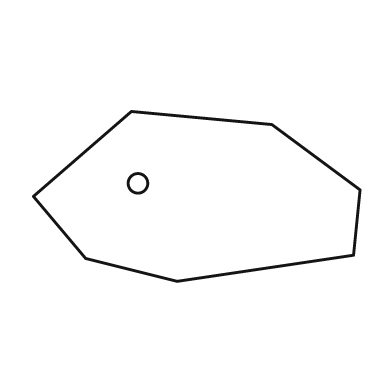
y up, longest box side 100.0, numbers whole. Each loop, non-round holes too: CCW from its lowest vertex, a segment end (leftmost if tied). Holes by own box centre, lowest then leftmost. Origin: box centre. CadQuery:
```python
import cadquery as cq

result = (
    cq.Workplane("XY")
    .moveTo(-6.0, -26.0)
    .lineTo(48.0, -18.0)
    .lineTo(50.0, 2.0)
    .lineTo(23.0, 22.0)
    .lineTo(-20.0, 26.0)
    .lineTo(-50.0, 0.0)
    .lineTo(-34.0, -19.0)
    .close()
    .moveTo(-18.0, 4.0)
    .circle(3.0)
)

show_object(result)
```